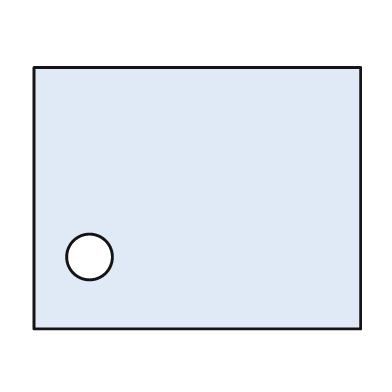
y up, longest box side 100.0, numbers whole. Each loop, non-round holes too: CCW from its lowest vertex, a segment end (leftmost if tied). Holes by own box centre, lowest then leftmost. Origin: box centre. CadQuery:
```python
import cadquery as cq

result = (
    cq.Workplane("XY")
    .moveTo(-50.0, -40.0)
    .lineTo(50.0, -40.0)
    .lineTo(50.0, 40.0)
    .lineTo(-50.0, 40.0)
    .close()
    .moveTo(-33.0, -18.0)
    .circle(7.0)
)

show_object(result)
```